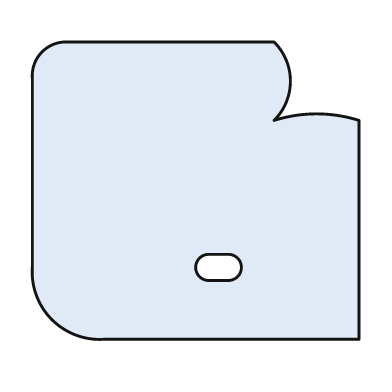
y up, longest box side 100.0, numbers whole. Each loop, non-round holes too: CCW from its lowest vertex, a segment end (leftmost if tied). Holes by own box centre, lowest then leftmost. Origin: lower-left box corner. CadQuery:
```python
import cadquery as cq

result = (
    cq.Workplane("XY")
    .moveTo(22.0, 0.0)
    .lineTo(100.0, 0.0)
    .lineTo(100.0, 67.0)
    .threePointArc((87.0, 69.0), (74.0, 67.0))
    .threePointArc((79.0, 79.0), (74.0, 91.0))
    .lineTo(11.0, 91.0)
    .threePointArc((3.0, 88.0), (0.0, 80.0))
    .lineTo(0.0, 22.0)
    .threePointArc((6.0, 6.0), (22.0, 0.0))
    .close()
    .moveTo(54.0, 18.0)
    .lineTo(60.0, 18.0)
    .threePointArc((64.0, 22.0), (60.0, 26.0))
    .lineTo(54.0, 26.0)
    .threePointArc((50.0, 22.0), (54.0, 18.0))
    .close()
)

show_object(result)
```